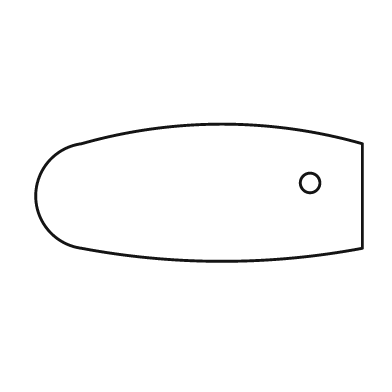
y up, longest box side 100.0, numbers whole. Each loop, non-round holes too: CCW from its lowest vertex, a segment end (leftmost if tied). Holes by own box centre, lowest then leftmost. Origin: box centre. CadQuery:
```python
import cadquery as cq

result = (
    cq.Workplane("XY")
    .moveTo(-36.0, -17.0)
    .threePointArc((7.0, -21.0), (50.0, -17.0))
    .lineTo(50.0, 15.0)
    .threePointArc((7.0, 21.0), (-36.0, 15.0))
    .threePointArc((-50.0, -1.0), (-36.0, -17.0))
    .close()
    .moveTo(34.0, 3.0)
    .circle(3.0)
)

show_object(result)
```